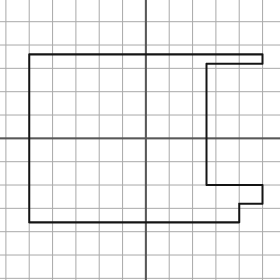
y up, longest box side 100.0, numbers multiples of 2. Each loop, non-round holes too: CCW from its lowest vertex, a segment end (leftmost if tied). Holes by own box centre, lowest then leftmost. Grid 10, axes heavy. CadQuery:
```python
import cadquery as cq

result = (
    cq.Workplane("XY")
    .moveTo(-50.0, -36.0)
    .lineTo(40.0, -36.0)
    .lineTo(40.0, -28.0)
    .lineTo(50.0, -28.0)
    .lineTo(50.0, -20.0)
    .lineTo(26.0, -20.0)
    .lineTo(26.0, 32.0)
    .lineTo(50.0, 32.0)
    .lineTo(50.0, 36.0)
    .lineTo(-50.0, 36.0)
    .close()
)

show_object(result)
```